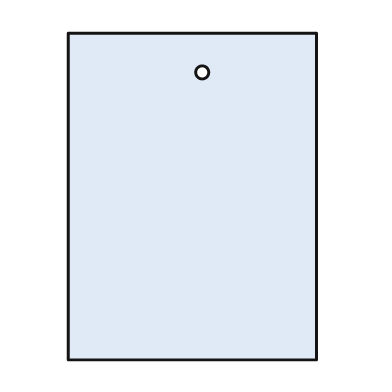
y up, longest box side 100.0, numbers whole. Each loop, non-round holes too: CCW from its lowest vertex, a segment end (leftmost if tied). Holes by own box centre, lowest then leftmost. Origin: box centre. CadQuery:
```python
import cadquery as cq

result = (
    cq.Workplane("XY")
    .moveTo(-38.0, -50.0)
    .lineTo(38.0, -50.0)
    .lineTo(38.0, 50.0)
    .lineTo(-38.0, 50.0)
    .close()
    .moveTo(3.0, 38.0)
    .circle(2.0)
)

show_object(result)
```